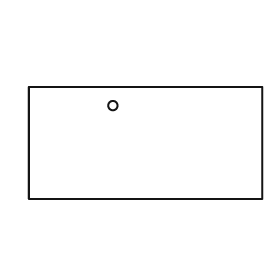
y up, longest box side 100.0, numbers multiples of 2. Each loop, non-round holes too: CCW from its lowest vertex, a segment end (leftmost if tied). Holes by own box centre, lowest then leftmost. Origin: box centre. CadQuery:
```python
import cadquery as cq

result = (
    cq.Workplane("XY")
    .moveTo(-50.0, -24.0)
    .lineTo(50.0, -24.0)
    .lineTo(50.0, 24.0)
    .lineTo(-50.0, 24.0)
    .close()
    .moveTo(-14.0, 16.0)
    .circle(2.0)
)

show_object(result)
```